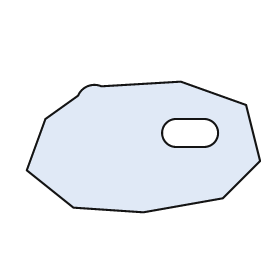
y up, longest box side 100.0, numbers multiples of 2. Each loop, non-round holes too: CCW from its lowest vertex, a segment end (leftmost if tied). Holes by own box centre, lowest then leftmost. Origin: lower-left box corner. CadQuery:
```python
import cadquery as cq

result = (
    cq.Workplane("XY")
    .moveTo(50.0, 0.0)
    .lineTo(84.0, 6.0)
    .lineTo(100.0, 22.0)
    .lineTo(94.0, 46.0)
    .lineTo(66.0, 56.0)
    .lineTo(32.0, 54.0)
    .threePointArc((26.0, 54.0), (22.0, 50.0))
    .lineTo(8.0, 40.0)
    .lineTo(0.0, 18.0)
    .lineTo(20.0, 2.0)
    .close()
    .moveTo(64.0, 28.0)
    .lineTo(76.0, 28.0)
    .threePointArc((82.0, 34.0), (76.0, 40.0))
    .lineTo(64.0, 40.0)
    .threePointArc((58.0, 34.0), (64.0, 28.0))
    .close()
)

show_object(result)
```